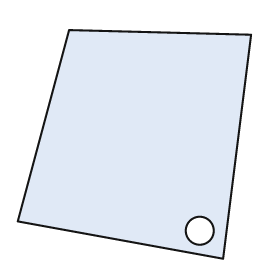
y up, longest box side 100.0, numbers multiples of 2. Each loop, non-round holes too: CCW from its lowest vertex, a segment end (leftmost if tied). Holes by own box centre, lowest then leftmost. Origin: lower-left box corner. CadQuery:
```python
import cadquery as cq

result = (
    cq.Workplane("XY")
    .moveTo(88.0, 0.0)
    .lineTo(100.0, 96.0)
    .lineTo(22.0, 98.0)
    .lineTo(0.0, 16.0)
    .close()
    .moveTo(78.0, 12.0)
    .circle(6.0)
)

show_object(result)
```